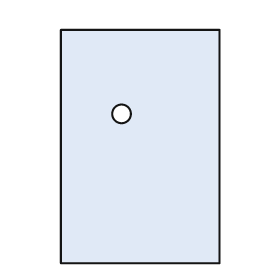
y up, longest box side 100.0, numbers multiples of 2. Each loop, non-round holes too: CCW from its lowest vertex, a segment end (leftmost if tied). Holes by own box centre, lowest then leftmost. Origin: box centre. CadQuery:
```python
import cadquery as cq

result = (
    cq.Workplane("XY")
    .moveTo(-34.0, -50.0)
    .lineTo(34.0, -50.0)
    .lineTo(34.0, 50.0)
    .lineTo(-34.0, 50.0)
    .close()
    .moveTo(-8.0, 14.0)
    .circle(4.0)
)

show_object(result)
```